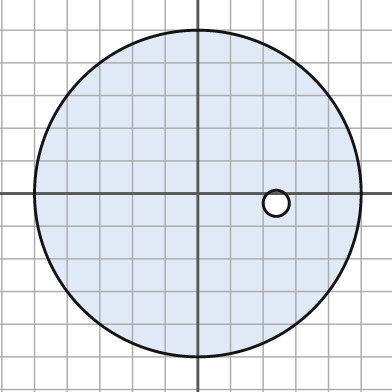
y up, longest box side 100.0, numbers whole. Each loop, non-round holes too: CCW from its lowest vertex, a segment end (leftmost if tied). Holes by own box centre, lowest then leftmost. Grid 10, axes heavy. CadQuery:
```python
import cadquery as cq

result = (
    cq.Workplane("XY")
    .moveTo(0.0, 0.0)
    .circle(50.0)
    .moveTo(24.0, -3.0)
    .circle(4.0)
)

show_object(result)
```